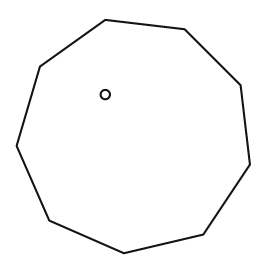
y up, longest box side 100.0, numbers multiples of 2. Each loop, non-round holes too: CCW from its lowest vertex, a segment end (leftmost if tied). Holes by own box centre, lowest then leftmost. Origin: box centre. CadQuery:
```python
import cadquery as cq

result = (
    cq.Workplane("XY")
    .moveTo(-4.0, -50.0)
    .lineTo(30.0, -42.0)
    .lineTo(50.0, -12.0)
    .lineTo(46.0, 22.0)
    .lineTo(22.0, 46.0)
    .lineTo(-12.0, 50.0)
    .lineTo(-40.0, 30.0)
    .lineTo(-50.0, -4.0)
    .lineTo(-36.0, -36.0)
    .close()
    .moveTo(-12.0, 18.0)
    .circle(2.0)
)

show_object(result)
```